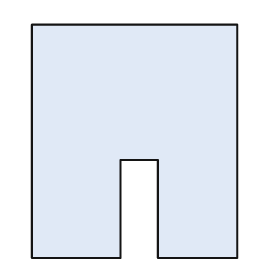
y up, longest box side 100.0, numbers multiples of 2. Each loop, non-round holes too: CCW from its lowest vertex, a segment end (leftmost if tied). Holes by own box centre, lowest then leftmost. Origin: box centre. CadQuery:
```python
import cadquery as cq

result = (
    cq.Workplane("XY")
    .moveTo(-44.0, -50.0)
    .lineTo(-6.0, -50.0)
    .lineTo(-6.0, -8.0)
    .lineTo(10.0, -8.0)
    .lineTo(10.0, -50.0)
    .lineTo(44.0, -50.0)
    .lineTo(44.0, 50.0)
    .lineTo(-44.0, 50.0)
    .close()
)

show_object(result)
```